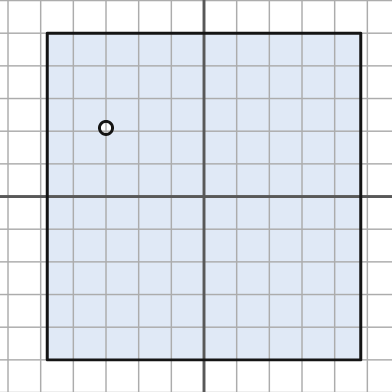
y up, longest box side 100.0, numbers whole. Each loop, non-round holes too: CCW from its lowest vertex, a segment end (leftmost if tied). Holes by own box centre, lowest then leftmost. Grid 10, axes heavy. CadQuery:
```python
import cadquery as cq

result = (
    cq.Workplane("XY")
    .moveTo(-48.0, -50.0)
    .lineTo(48.0, -50.0)
    .lineTo(48.0, 50.0)
    .lineTo(-48.0, 50.0)
    .close()
    .moveTo(-30.0, 21.0)
    .circle(2.0)
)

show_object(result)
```